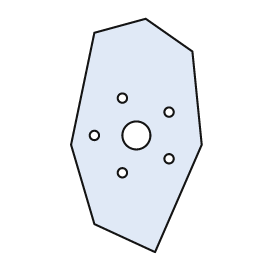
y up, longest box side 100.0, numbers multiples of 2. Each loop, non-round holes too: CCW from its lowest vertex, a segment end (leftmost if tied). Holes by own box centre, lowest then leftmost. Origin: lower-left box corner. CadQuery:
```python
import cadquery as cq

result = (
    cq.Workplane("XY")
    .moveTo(36.0, 0.0)
    .lineTo(56.0, 46.0)
    .lineTo(52.0, 86.0)
    .lineTo(32.0, 100.0)
    .lineTo(10.0, 94.0)
    .lineTo(0.0, 46.0)
    .lineTo(10.0, 12.0)
    .close()
    .moveTo(22.0, 34.0)
    .circle(2.0)
    .moveTo(42.0, 40.0)
    .circle(2.0)
    .moveTo(10.0, 50.0)
    .circle(2.0)
    .moveTo(28.0, 50.0)
    .circle(6.0)
    .moveTo(42.0, 60.0)
    .circle(2.0)
    .moveTo(22.0, 66.0)
    .circle(2.0)
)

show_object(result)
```